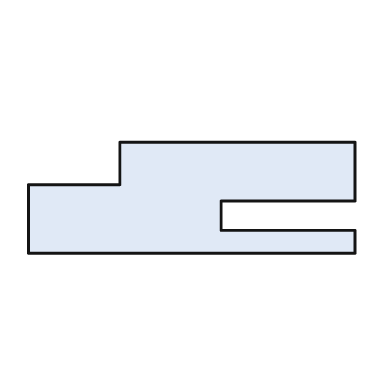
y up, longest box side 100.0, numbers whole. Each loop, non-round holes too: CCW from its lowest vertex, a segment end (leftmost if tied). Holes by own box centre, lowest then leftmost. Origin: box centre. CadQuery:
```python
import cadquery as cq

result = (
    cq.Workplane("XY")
    .moveTo(-50.0, -17.0)
    .lineTo(50.0, -17.0)
    .lineTo(50.0, -10.0)
    .lineTo(9.0, -10.0)
    .lineTo(9.0, -1.0)
    .lineTo(50.0, -1.0)
    .lineTo(50.0, 17.0)
    .lineTo(-22.0, 17.0)
    .lineTo(-22.0, 4.0)
    .lineTo(-50.0, 4.0)
    .close()
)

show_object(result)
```